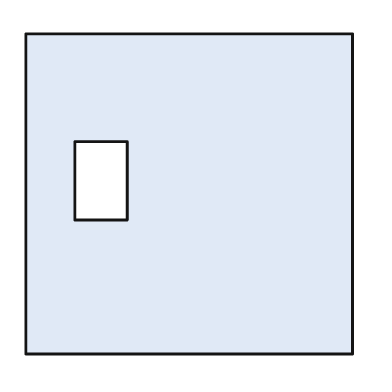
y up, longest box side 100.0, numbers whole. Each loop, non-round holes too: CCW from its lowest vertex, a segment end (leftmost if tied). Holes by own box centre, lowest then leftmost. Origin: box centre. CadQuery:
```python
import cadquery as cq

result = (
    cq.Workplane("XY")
    .moveTo(-50.0, -49.0)
    .lineTo(50.0, -49.0)
    .lineTo(50.0, 49.0)
    .lineTo(-50.0, 49.0)
    .close()
    .moveTo(-35.0, -8.0)
    .lineTo(-19.0, -8.0)
    .lineTo(-19.0, 16.0)
    .lineTo(-35.0, 16.0)
    .close()
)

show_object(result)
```